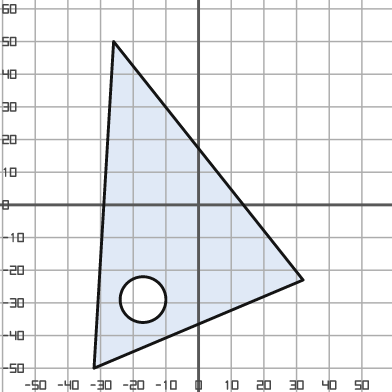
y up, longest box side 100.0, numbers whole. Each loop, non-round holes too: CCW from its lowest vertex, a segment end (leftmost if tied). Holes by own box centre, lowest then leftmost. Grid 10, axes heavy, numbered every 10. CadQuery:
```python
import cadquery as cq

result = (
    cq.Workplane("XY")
    .moveTo(-32.0, -50.0)
    .lineTo(32.0, -23.0)
    .lineTo(-26.0, 50.0)
    .close()
    .moveTo(-17.0, -29.0)
    .circle(7.0)
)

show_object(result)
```